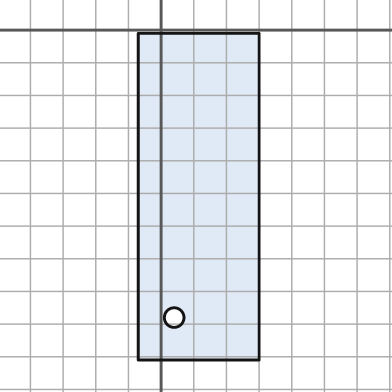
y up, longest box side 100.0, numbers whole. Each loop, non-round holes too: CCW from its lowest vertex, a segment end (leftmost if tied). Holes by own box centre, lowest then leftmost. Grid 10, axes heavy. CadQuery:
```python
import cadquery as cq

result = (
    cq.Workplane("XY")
    .moveTo(-7.0, -101.0)
    .lineTo(30.0, -101.0)
    .lineTo(30.0, -1.0)
    .lineTo(-7.0, -1.0)
    .close()
    .moveTo(4.0, -88.0)
    .circle(3.0)
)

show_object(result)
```